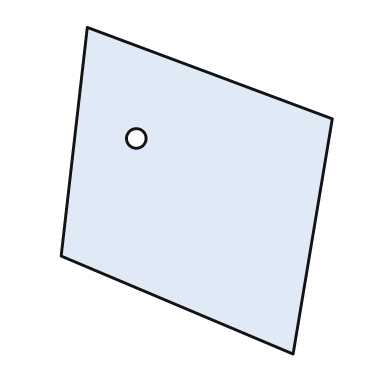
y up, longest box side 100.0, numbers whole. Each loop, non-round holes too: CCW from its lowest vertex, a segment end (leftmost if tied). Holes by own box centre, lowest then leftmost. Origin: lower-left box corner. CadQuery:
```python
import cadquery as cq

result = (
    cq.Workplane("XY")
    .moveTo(71.0, 0.0)
    .lineTo(83.0, 72.0)
    .lineTo(8.0, 100.0)
    .lineTo(0.0, 30.0)
    .close()
    .moveTo(23.0, 66.0)
    .circle(3.0)
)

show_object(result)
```